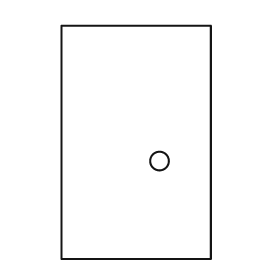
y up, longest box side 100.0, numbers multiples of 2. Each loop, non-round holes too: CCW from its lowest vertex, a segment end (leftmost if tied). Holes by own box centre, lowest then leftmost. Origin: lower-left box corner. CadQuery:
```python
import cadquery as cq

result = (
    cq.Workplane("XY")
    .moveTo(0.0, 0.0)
    .lineTo(64.0, 0.0)
    .lineTo(64.0, 100.0)
    .lineTo(0.0, 100.0)
    .close()
    .moveTo(42.0, 42.0)
    .circle(4.0)
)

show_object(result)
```